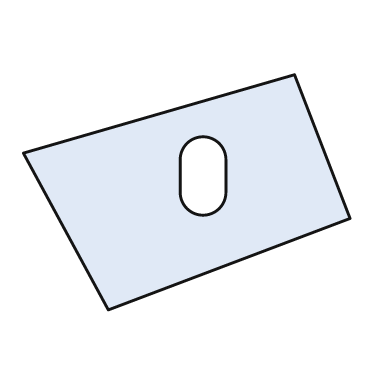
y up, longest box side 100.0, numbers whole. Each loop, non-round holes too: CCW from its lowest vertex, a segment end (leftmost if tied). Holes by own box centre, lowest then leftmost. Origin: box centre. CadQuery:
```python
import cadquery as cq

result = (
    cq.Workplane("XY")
    .moveTo(-24.0, -36.0)
    .lineTo(50.0, -8.0)
    .lineTo(33.0, 36.0)
    .lineTo(-50.0, 12.0)
    .close()
    .moveTo(-2.0, 0.0)
    .threePointArc((5.0, -7.0), (12.0, 0.0))
    .lineTo(12.0, 10.0)
    .threePointArc((5.0, 17.0), (-2.0, 10.0))
    .close()
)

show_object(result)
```